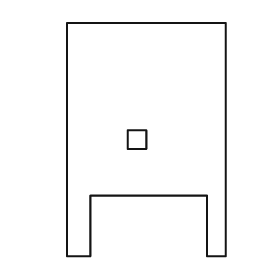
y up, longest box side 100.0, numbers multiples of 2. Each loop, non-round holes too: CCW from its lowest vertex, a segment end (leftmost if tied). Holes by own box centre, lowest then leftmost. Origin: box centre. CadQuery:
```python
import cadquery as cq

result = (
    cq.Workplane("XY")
    .moveTo(-34.0, -50.0)
    .lineTo(-24.0, -50.0)
    .lineTo(-24.0, -24.0)
    .lineTo(26.0, -24.0)
    .lineTo(26.0, -50.0)
    .lineTo(34.0, -50.0)
    .lineTo(34.0, 50.0)
    .lineTo(-34.0, 50.0)
    .close()
    .moveTo(-8.0, -4.0)
    .lineTo(0.0, -4.0)
    .lineTo(0.0, 4.0)
    .lineTo(-8.0, 4.0)
    .close()
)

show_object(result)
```